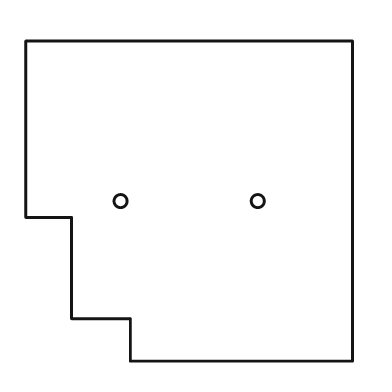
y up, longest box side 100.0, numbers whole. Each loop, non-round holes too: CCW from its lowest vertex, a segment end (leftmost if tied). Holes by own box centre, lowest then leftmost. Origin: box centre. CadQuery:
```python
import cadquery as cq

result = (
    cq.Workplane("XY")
    .moveTo(-18.0, -49.0)
    .lineTo(50.0, -49.0)
    .lineTo(50.0, 49.0)
    .lineTo(-50.0, 49.0)
    .lineTo(-50.0, -5.0)
    .lineTo(-36.0, -5.0)
    .lineTo(-36.0, -36.0)
    .lineTo(-18.0, -36.0)
    .close()
    .moveTo(-21.0, 0.0)
    .circle(2.0)
    .moveTo(21.0, 0.0)
    .circle(2.0)
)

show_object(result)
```